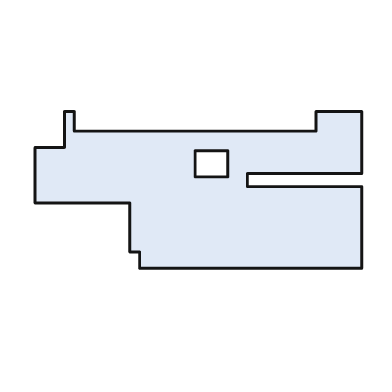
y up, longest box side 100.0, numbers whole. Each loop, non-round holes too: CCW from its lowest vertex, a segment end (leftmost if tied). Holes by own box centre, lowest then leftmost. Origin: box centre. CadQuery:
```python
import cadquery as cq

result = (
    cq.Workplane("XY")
    .moveTo(-18.0, -24.0)
    .lineTo(50.0, -24.0)
    .lineTo(50.0, 1.0)
    .lineTo(15.0, 1.0)
    .lineTo(15.0, 5.0)
    .lineTo(50.0, 5.0)
    .lineTo(50.0, 24.0)
    .lineTo(36.0, 24.0)
    .lineTo(36.0, 18.0)
    .lineTo(-38.0, 18.0)
    .lineTo(-38.0, 24.0)
    .lineTo(-41.0, 24.0)
    .lineTo(-41.0, 13.0)
    .lineTo(-50.0, 13.0)
    .lineTo(-50.0, -4.0)
    .lineTo(-21.0, -4.0)
    .lineTo(-21.0, -19.0)
    .lineTo(-18.0, -19.0)
    .close()
    .moveTo(-1.0, 4.0)
    .lineTo(9.0, 4.0)
    .lineTo(9.0, 12.0)
    .lineTo(-1.0, 12.0)
    .close()
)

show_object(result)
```